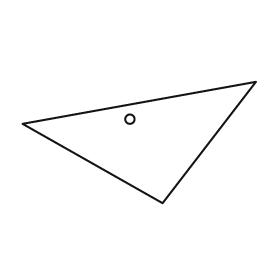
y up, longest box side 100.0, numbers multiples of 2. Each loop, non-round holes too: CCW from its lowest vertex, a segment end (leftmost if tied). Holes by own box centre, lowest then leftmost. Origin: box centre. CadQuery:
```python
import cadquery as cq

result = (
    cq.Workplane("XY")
    .moveTo(10.0, -26.0)
    .lineTo(50.0, 26.0)
    .lineTo(-50.0, 8.0)
    .close()
    .moveTo(-4.0, 10.0)
    .circle(2.0)
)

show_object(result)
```